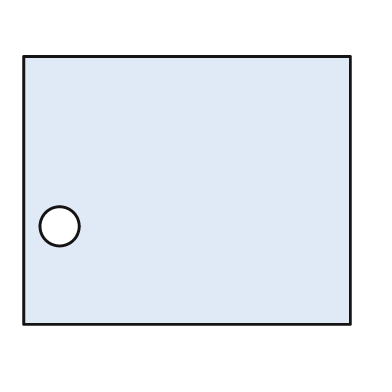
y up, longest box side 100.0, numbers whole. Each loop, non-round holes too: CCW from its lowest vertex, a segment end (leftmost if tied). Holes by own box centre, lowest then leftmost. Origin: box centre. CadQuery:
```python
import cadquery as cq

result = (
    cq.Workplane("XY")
    .moveTo(-50.0, -41.0)
    .lineTo(50.0, -41.0)
    .lineTo(50.0, 41.0)
    .lineTo(-50.0, 41.0)
    .close()
    .moveTo(-39.0, -11.0)
    .circle(6.0)
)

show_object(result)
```